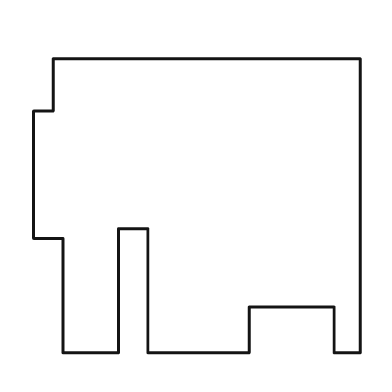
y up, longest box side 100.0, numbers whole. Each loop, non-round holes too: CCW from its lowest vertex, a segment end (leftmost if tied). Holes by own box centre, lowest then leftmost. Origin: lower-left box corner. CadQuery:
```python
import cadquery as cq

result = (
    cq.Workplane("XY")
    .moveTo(9.0, 0.0)
    .lineTo(26.0, 0.0)
    .lineTo(26.0, 38.0)
    .lineTo(35.0, 38.0)
    .lineTo(35.0, 0.0)
    .lineTo(66.0, 0.0)
    .lineTo(66.0, 14.0)
    .lineTo(92.0, 14.0)
    .lineTo(92.0, 0.0)
    .lineTo(100.0, 0.0)
    .lineTo(100.0, 90.0)
    .lineTo(6.0, 90.0)
    .lineTo(6.0, 74.0)
    .lineTo(0.0, 74.0)
    .lineTo(0.0, 35.0)
    .lineTo(9.0, 35.0)
    .close()
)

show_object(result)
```